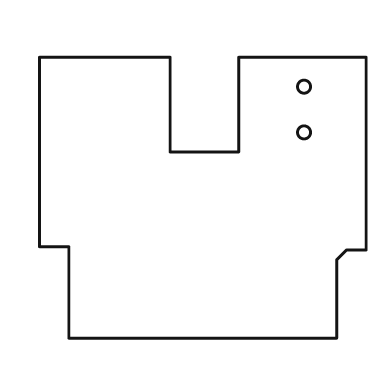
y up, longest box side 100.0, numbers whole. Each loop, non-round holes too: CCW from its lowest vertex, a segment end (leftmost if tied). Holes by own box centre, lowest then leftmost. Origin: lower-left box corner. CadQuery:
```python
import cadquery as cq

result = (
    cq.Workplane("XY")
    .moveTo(9.0, 0.0)
    .lineTo(91.0, 0.0)
    .lineTo(91.0, 24.0)
    .lineTo(94.0, 27.0)
    .lineTo(100.0, 27.0)
    .lineTo(100.0, 86.0)
    .lineTo(61.0, 86.0)
    .lineTo(61.0, 57.0)
    .lineTo(40.0, 57.0)
    .lineTo(40.0, 86.0)
    .lineTo(0.0, 86.0)
    .lineTo(0.0, 28.0)
    .lineTo(9.0, 28.0)
    .close()
    .moveTo(81.0, 63.0)
    .circle(2.0)
    .moveTo(81.0, 77.0)
    .circle(2.0)
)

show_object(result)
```